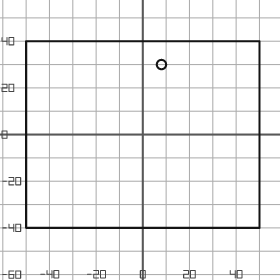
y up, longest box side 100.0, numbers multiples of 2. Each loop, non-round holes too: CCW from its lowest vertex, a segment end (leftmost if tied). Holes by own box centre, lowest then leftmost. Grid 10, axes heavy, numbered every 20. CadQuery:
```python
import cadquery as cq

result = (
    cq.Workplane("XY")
    .moveTo(-50.0, -40.0)
    .lineTo(50.0, -40.0)
    .lineTo(50.0, 40.0)
    .lineTo(-50.0, 40.0)
    .close()
    .moveTo(8.0, 30.0)
    .circle(2.0)
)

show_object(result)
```